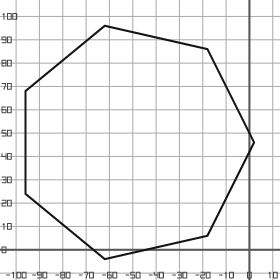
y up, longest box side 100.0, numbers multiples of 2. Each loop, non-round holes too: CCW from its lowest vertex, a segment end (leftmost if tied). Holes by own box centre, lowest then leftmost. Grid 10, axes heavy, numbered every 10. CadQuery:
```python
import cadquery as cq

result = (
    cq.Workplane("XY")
    .moveTo(-62.0, -4.0)
    .lineTo(-18.0, 6.0)
    .lineTo(2.0, 46.0)
    .lineTo(-18.0, 86.0)
    .lineTo(-62.0, 96.0)
    .lineTo(-96.0, 68.0)
    .lineTo(-96.0, 24.0)
    .close()
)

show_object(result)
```